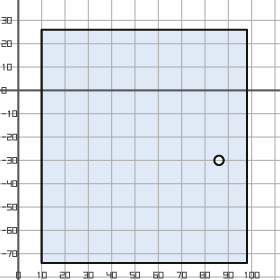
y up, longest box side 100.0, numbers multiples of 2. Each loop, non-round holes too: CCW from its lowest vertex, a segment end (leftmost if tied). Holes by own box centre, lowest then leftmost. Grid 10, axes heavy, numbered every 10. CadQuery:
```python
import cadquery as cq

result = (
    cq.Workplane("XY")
    .moveTo(10.0, -74.0)
    .lineTo(98.0, -74.0)
    .lineTo(98.0, 26.0)
    .lineTo(10.0, 26.0)
    .close()
    .moveTo(86.0, -30.0)
    .circle(2.0)
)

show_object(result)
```